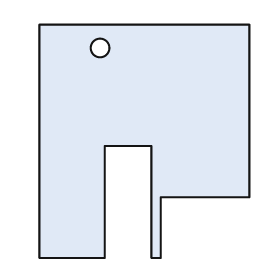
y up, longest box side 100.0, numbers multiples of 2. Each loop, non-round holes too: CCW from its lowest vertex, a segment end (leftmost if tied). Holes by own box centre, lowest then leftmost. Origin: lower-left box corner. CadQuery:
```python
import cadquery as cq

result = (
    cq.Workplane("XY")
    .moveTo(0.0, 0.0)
    .lineTo(28.0, 0.0)
    .lineTo(28.0, 48.0)
    .lineTo(48.0, 48.0)
    .lineTo(48.0, 0.0)
    .lineTo(52.0, 0.0)
    .lineTo(52.0, 26.0)
    .lineTo(90.0, 26.0)
    .lineTo(90.0, 100.0)
    .lineTo(0.0, 100.0)
    .close()
    .moveTo(26.0, 90.0)
    .circle(4.0)
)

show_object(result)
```